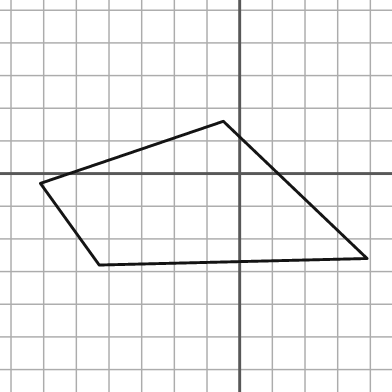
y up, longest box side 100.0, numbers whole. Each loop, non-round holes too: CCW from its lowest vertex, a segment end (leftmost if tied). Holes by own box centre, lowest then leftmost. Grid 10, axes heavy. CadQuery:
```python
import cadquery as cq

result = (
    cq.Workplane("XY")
    .moveTo(-43.0, -28.0)
    .lineTo(39.0, -26.0)
    .lineTo(-5.0, 16.0)
    .lineTo(-61.0, -3.0)
    .close()
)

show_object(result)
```